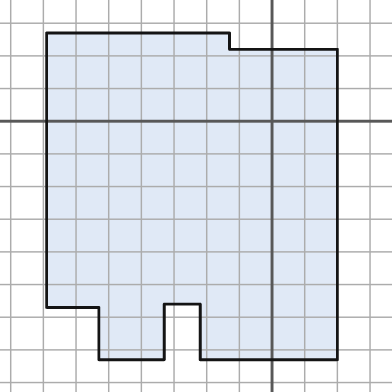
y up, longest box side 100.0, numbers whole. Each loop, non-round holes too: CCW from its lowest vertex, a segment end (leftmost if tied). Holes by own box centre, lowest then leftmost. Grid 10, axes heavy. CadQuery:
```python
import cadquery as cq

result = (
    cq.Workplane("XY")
    .moveTo(-53.0, -73.0)
    .lineTo(-33.0, -73.0)
    .lineTo(-33.0, -56.0)
    .lineTo(-22.0, -56.0)
    .lineTo(-22.0, -73.0)
    .lineTo(20.0, -73.0)
    .lineTo(20.0, 22.0)
    .lineTo(-13.0, 22.0)
    .lineTo(-13.0, 27.0)
    .lineTo(-69.0, 27.0)
    .lineTo(-69.0, -57.0)
    .lineTo(-53.0, -57.0)
    .close()
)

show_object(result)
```